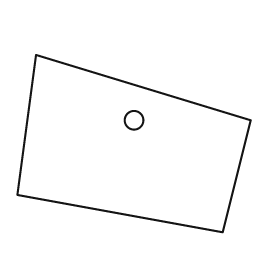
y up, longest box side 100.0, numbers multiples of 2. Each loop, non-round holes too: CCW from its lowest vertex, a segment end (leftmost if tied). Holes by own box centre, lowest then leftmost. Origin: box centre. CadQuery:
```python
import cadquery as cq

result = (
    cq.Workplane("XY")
    .moveTo(38.0, -38.0)
    .lineTo(50.0, 10.0)
    .lineTo(-42.0, 38.0)
    .lineTo(-50.0, -22.0)
    .close()
    .moveTo(0.0, 10.0)
    .circle(4.0)
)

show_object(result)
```